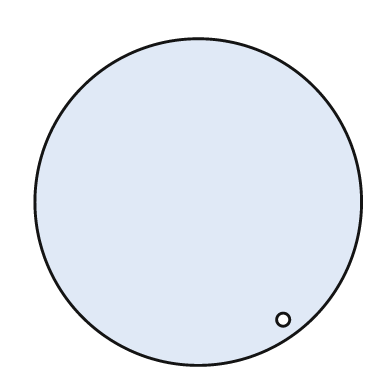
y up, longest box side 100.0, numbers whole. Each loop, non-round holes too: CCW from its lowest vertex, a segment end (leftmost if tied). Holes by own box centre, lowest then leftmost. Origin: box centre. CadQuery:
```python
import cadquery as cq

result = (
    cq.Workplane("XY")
    .moveTo(0.0, 0.0)
    .circle(50.0)
    .moveTo(26.0, -36.0)
    .circle(2.0)
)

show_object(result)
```